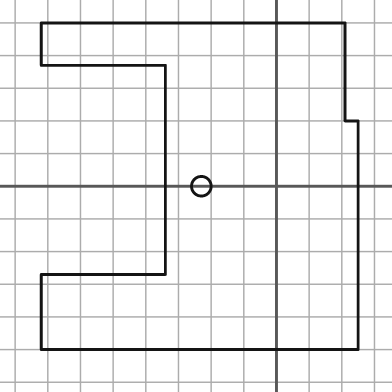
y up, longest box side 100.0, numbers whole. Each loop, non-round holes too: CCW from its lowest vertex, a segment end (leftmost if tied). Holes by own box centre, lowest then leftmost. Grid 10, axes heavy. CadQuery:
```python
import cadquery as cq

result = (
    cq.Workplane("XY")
    .moveTo(-72.0, -50.0)
    .lineTo(25.0, -50.0)
    .lineTo(25.0, 20.0)
    .lineTo(21.0, 20.0)
    .lineTo(21.0, 50.0)
    .lineTo(-72.0, 50.0)
    .lineTo(-72.0, 37.0)
    .lineTo(-34.0, 37.0)
    .lineTo(-34.0, -27.0)
    .lineTo(-72.0, -27.0)
    .close()
    .moveTo(-23.0, 0.0)
    .circle(3.0)
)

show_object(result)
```